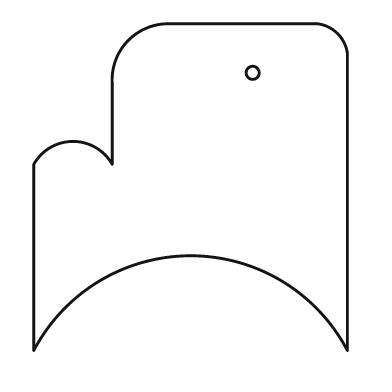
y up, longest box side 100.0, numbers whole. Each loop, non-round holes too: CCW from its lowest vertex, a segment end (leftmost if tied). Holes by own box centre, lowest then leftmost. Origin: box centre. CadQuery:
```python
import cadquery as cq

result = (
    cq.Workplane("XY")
    .moveTo(-48.0, -50.0)
    .threePointArc((0.0, -21.0), (48.0, -50.0))
    .lineTo(48.0, 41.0)
    .threePointArc((45.0, 47.0), (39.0, 50.0))
    .lineTo(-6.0, 50.0)
    .threePointArc((-19.0, 45.0), (-24.0, 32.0))
    .lineTo(-24.0, 7.0)
    .threePointArc((-36.0, 14.0), (-48.0, 7.0))
    .close()
    .moveTo(19.0, 35.0)
    .circle(2.0)
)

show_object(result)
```